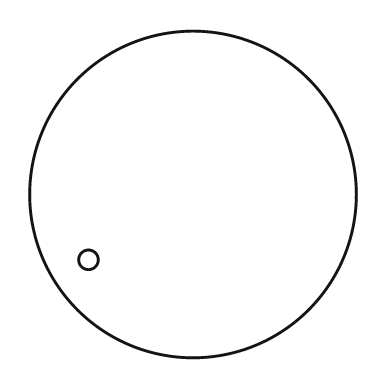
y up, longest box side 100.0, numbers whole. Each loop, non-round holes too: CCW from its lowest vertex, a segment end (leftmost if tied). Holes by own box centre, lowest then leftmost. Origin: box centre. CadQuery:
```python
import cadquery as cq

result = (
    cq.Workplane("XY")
    .moveTo(0.0, 0.0)
    .circle(50.0)
    .moveTo(-32.0, -20.0)
    .circle(3.0)
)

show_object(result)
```